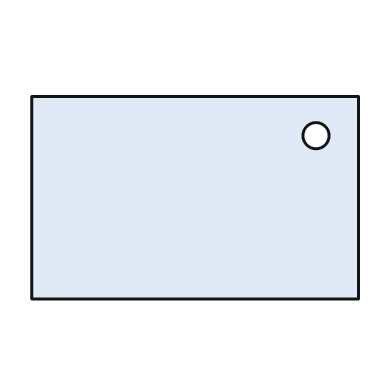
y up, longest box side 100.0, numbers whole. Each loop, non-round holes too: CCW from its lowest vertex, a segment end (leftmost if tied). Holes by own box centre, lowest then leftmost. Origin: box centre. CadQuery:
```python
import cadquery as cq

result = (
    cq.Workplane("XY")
    .moveTo(-50.0, -31.0)
    .lineTo(50.0, -31.0)
    .lineTo(50.0, 31.0)
    .lineTo(-50.0, 31.0)
    .close()
    .moveTo(37.0, 19.0)
    .circle(4.0)
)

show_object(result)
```